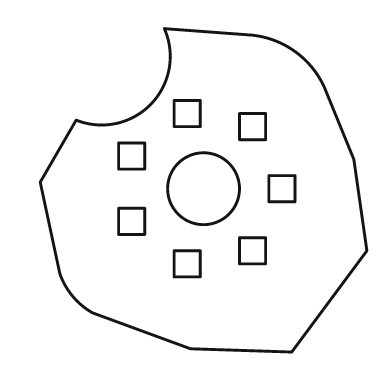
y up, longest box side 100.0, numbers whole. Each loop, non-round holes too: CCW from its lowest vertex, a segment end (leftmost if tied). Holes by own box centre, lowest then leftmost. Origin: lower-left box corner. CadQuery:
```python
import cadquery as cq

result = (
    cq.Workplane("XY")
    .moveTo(77.0, 0.0)
    .lineTo(100.0, 31.0)
    .lineTo(96.0, 59.0)
    .lineTo(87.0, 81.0)
    .threePointArc((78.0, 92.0), (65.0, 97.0))
    .lineTo(38.0, 99.0)
    .threePointArc((34.0, 76.0), (11.0, 71.0))
    .lineTo(0.0, 52.0)
    .lineTo(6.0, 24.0)
    .threePointArc((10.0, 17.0), (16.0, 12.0))
    .lineTo(46.0, 1.0)
    .close()
    .moveTo(41.0, 23.0)
    .lineTo(49.0, 23.0)
    .lineTo(49.0, 31.0)
    .lineTo(41.0, 31.0)
    .close()
    .moveTo(61.0, 27.0)
    .lineTo(69.0, 27.0)
    .lineTo(69.0, 35.0)
    .lineTo(61.0, 35.0)
    .close()
    .moveTo(24.0, 36.0)
    .lineTo(32.0, 36.0)
    .lineTo(32.0, 44.0)
    .lineTo(24.0, 44.0)
    .close()
    .moveTo(50.0, 50.0)
    .circle(11.0)
    .moveTo(70.0, 46.0)
    .lineTo(78.0, 46.0)
    .lineTo(78.0, 54.0)
    .lineTo(70.0, 54.0)
    .close()
    .moveTo(24.0, 56.0)
    .lineTo(32.0, 56.0)
    .lineTo(32.0, 64.0)
    .lineTo(24.0, 64.0)
    .close()
    .moveTo(61.0, 65.0)
    .lineTo(69.0, 65.0)
    .lineTo(69.0, 73.0)
    .lineTo(61.0, 73.0)
    .close()
    .moveTo(41.0, 69.0)
    .lineTo(49.0, 69.0)
    .lineTo(49.0, 77.0)
    .lineTo(41.0, 77.0)
    .close()
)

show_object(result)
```